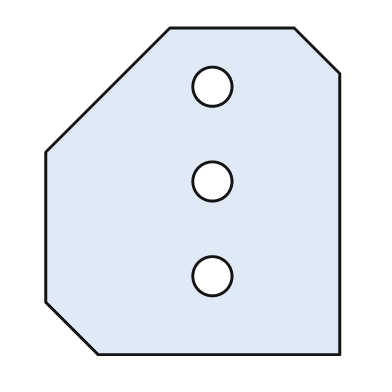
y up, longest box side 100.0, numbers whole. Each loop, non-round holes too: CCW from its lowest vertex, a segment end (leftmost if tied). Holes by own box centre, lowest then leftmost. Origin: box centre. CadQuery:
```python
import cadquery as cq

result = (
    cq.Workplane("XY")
    .moveTo(-29.0, -50.0)
    .lineTo(45.0, -50.0)
    .lineTo(45.0, 36.0)
    .lineTo(31.0, 50.0)
    .lineTo(-7.0, 50.0)
    .lineTo(-45.0, 12.0)
    .lineTo(-45.0, -34.0)
    .close()
    .moveTo(6.0, -26.0)
    .circle(6.0)
    .moveTo(6.0, 3.0)
    .circle(6.0)
    .moveTo(6.0, 32.0)
    .circle(6.0)
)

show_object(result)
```